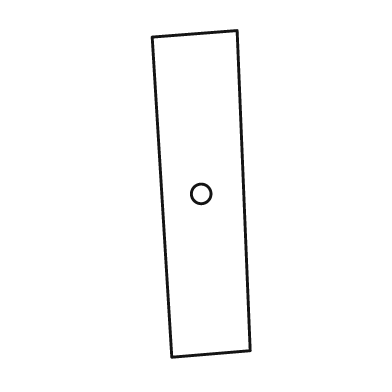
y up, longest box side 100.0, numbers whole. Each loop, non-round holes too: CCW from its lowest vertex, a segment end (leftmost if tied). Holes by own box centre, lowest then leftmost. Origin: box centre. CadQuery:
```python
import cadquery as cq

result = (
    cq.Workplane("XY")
    .moveTo(-9.0, -50.0)
    .lineTo(15.0, -48.0)
    .lineTo(11.0, 50.0)
    .lineTo(-15.0, 48.0)
    .close()
    .moveTo(0.0, 0.0)
    .circle(3.0)
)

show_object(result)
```